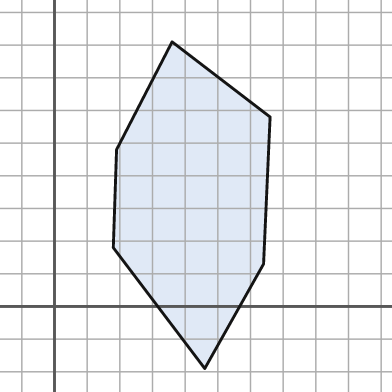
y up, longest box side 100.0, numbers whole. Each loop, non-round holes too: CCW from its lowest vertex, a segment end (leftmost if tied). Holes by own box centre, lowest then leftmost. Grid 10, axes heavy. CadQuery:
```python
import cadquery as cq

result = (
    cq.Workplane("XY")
    .moveTo(46.0, -19.0)
    .lineTo(64.0, 13.0)
    .lineTo(66.0, 58.0)
    .lineTo(36.0, 81.0)
    .lineTo(19.0, 48.0)
    .lineTo(18.0, 18.0)
    .close()
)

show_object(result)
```